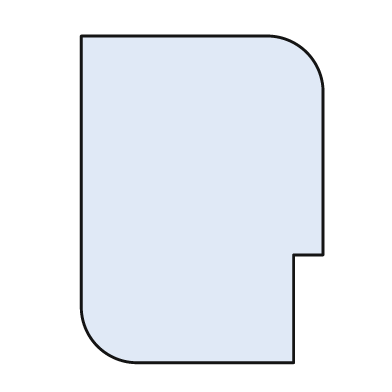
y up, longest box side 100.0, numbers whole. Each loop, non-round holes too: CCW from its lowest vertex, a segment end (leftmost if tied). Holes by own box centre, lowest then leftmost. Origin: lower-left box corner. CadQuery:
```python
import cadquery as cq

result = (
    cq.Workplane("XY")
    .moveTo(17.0, 0.0)
    .lineTo(65.0, 0.0)
    .lineTo(65.0, 33.0)
    .lineTo(74.0, 33.0)
    .lineTo(74.0, 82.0)
    .threePointArc((69.0, 95.0), (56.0, 100.0))
    .lineTo(0.0, 100.0)
    .lineTo(0.0, 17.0)
    .threePointArc((5.0, 5.0), (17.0, 0.0))
    .close()
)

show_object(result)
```